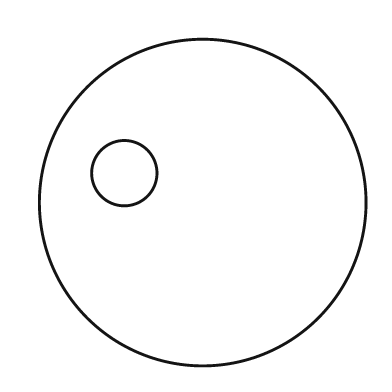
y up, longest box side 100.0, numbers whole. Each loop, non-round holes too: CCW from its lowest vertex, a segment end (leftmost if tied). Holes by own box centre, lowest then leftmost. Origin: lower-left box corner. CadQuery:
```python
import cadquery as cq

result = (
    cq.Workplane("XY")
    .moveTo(50.0, 50.0)
    .circle(50.0)
    .moveTo(26.0, 59.0)
    .circle(10.0)
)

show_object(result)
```